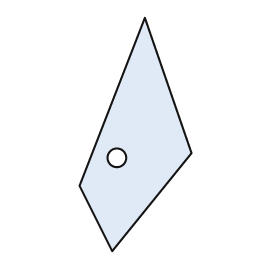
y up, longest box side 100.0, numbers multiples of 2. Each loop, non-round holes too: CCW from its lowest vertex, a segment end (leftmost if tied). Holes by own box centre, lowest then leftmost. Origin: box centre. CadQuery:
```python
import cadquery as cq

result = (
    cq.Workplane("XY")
    .moveTo(-10.0, -50.0)
    .lineTo(24.0, -8.0)
    .lineTo(4.0, 50.0)
    .lineTo(-24.0, -22.0)
    .close()
    .moveTo(-8.0, -10.0)
    .circle(4.0)
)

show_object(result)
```